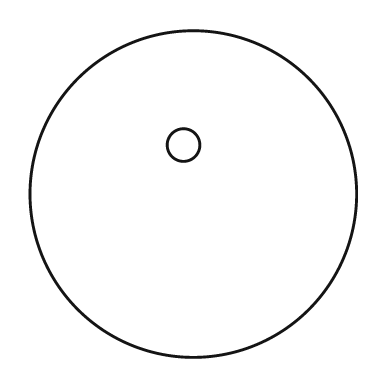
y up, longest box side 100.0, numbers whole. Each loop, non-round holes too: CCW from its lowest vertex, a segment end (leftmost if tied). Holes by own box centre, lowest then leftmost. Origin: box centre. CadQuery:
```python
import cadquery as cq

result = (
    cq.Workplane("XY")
    .moveTo(0.0, 0.0)
    .circle(50.0)
    .moveTo(-3.0, 15.0)
    .circle(5.0)
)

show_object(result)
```